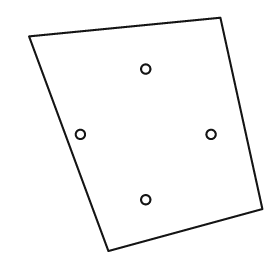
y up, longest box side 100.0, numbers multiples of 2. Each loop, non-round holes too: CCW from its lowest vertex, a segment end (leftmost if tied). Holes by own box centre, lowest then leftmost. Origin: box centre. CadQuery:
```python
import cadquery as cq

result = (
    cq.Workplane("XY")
    .moveTo(-16.0, -50.0)
    .lineTo(50.0, -32.0)
    .lineTo(32.0, 50.0)
    .lineTo(-50.0, 42.0)
    .close()
    .moveTo(0.0, -28.0)
    .circle(2.0)
    .moveTo(-28.0, 0.0)
    .circle(2.0)
    .moveTo(28.0, 0.0)
    .circle(2.0)
    .moveTo(0.0, 28.0)
    .circle(2.0)
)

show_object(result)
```